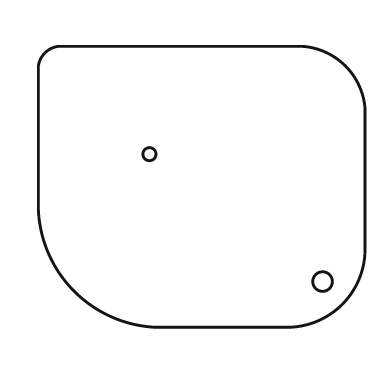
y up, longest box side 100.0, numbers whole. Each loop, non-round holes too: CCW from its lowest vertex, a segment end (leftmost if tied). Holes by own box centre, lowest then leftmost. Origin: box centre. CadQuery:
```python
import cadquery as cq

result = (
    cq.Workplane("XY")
    .moveTo(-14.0, -43.0)
    .lineTo(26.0, -43.0)
    .threePointArc((43.0, -36.0), (50.0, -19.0))
    .lineTo(50.0, 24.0)
    .threePointArc((44.0, 37.0), (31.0, 43.0))
    .lineTo(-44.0, 43.0)
    .threePointArc((-48.0, 41.0), (-50.0, 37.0))
    .lineTo(-50.0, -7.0)
    .threePointArc((-39.0, -32.0), (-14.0, -43.0))
    .close()
    .moveTo(37.0, -29.0)
    .circle(3.0)
    .moveTo(-16.0, 10.0)
    .circle(2.0)
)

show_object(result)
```